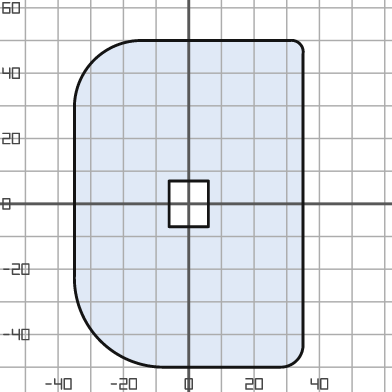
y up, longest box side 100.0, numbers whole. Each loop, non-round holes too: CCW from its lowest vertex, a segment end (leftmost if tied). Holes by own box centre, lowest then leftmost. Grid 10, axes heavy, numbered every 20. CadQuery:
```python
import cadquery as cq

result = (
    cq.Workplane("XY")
    .moveTo(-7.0, -50.0)
    .lineTo(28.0, -50.0)
    .threePointArc((33.0, -48.0), (35.0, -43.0))
    .lineTo(35.0, 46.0)
    .threePointArc((34.0, 49.0), (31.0, 50.0))
    .lineTo(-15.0, 50.0)
    .threePointArc((-29.0, 44.0), (-35.0, 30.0))
    .lineTo(-35.0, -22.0)
    .threePointArc((-27.0, -42.0), (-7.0, -50.0))
    .close()
    .moveTo(-6.0, -7.0)
    .lineTo(6.0, -7.0)
    .lineTo(6.0, 7.0)
    .lineTo(-6.0, 7.0)
    .close()
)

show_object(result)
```